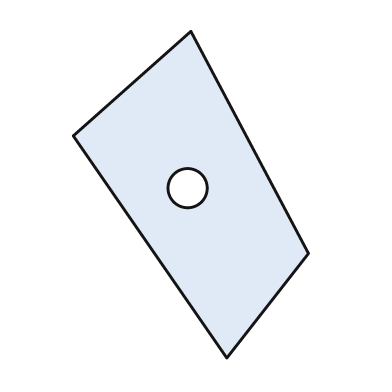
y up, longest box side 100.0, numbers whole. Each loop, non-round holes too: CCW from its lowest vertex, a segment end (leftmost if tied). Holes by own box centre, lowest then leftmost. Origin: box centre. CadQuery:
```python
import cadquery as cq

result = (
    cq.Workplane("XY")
    .moveTo(11.0, -50.0)
    .lineTo(36.0, -18.0)
    .lineTo(0.0, 50.0)
    .lineTo(-36.0, 18.0)
    .close()
    .moveTo(-1.0, 2.0)
    .circle(6.0)
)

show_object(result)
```